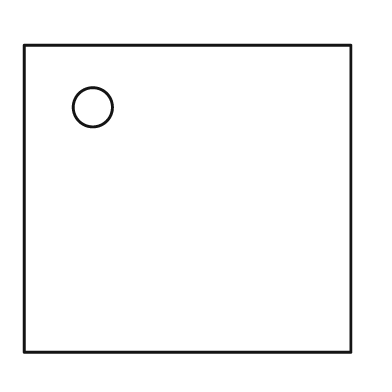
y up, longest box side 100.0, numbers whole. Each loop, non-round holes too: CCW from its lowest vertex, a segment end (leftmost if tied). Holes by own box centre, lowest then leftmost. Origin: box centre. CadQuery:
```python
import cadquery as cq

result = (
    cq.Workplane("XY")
    .moveTo(-50.0, -47.0)
    .lineTo(50.0, -47.0)
    .lineTo(50.0, 47.0)
    .lineTo(-50.0, 47.0)
    .close()
    .moveTo(-29.0, 28.0)
    .circle(6.0)
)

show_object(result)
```